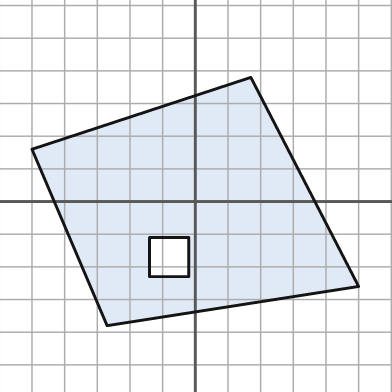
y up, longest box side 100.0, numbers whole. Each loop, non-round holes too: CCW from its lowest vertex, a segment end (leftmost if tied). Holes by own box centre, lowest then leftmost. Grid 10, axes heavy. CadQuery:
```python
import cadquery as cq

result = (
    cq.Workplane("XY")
    .moveTo(-27.0, -38.0)
    .lineTo(50.0, -26.0)
    .lineTo(17.0, 38.0)
    .lineTo(-50.0, 16.0)
    .close()
    .moveTo(-14.0, -23.0)
    .lineTo(-2.0, -23.0)
    .lineTo(-2.0, -11.0)
    .lineTo(-14.0, -11.0)
    .close()
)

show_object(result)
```